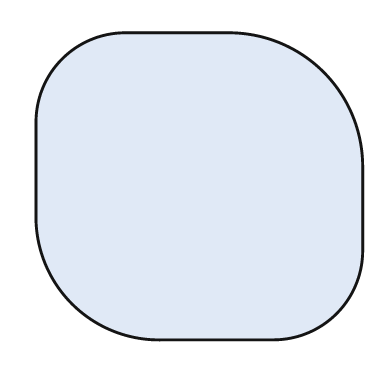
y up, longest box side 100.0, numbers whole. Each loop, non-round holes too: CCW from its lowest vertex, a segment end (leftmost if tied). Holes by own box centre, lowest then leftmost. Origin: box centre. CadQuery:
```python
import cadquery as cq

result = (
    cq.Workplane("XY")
    .moveTo(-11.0, -47.0)
    .lineTo(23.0, -47.0)
    .threePointArc((42.0, -39.0), (50.0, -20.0))
    .lineTo(50.0, 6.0)
    .threePointArc((38.0, 35.0), (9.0, 47.0))
    .lineTo(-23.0, 47.0)
    .threePointArc((-42.0, 39.0), (-50.0, 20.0))
    .lineTo(-50.0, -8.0)
    .threePointArc((-39.0, -36.0), (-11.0, -47.0))
    .close()
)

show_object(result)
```